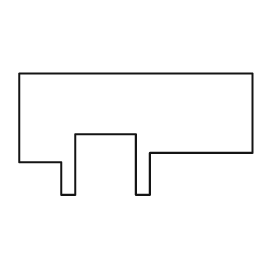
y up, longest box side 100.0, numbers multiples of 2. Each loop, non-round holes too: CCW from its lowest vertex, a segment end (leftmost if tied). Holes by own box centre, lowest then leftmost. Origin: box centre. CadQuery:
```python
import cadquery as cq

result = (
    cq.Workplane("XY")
    .moveTo(-32.0, -26.0)
    .lineTo(-26.0, -26.0)
    .lineTo(-26.0, 0.0)
    .lineTo(0.0, 0.0)
    .lineTo(0.0, -26.0)
    .lineTo(6.0, -26.0)
    .lineTo(6.0, -8.0)
    .lineTo(50.0, -8.0)
    .lineTo(50.0, 26.0)
    .lineTo(-50.0, 26.0)
    .lineTo(-50.0, -12.0)
    .lineTo(-32.0, -12.0)
    .close()
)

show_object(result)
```